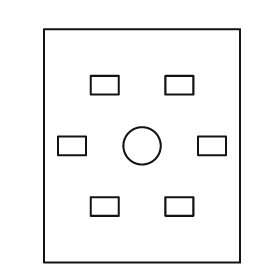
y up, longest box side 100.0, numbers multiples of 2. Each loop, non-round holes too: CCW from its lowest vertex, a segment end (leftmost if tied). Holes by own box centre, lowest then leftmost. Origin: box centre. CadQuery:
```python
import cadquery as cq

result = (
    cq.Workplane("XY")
    .moveTo(-42.0, -50.0)
    .lineTo(42.0, -50.0)
    .lineTo(42.0, 50.0)
    .lineTo(-42.0, 50.0)
    .close()
    .moveTo(-22.0, -30.0)
    .lineTo(-10.0, -30.0)
    .lineTo(-10.0, -22.0)
    .lineTo(-22.0, -22.0)
    .close()
    .moveTo(10.0, -30.0)
    .lineTo(22.0, -30.0)
    .lineTo(22.0, -22.0)
    .lineTo(10.0, -22.0)
    .close()
    .moveTo(-36.0, -4.0)
    .lineTo(-24.0, -4.0)
    .lineTo(-24.0, 4.0)
    .lineTo(-36.0, 4.0)
    .close()
    .moveTo(0.0, 0.0)
    .circle(8.0)
    .moveTo(24.0, -4.0)
    .lineTo(36.0, -4.0)
    .lineTo(36.0, 4.0)
    .lineTo(24.0, 4.0)
    .close()
    .moveTo(-22.0, 22.0)
    .lineTo(-10.0, 22.0)
    .lineTo(-10.0, 30.0)
    .lineTo(-22.0, 30.0)
    .close()
    .moveTo(10.0, 22.0)
    .lineTo(22.0, 22.0)
    .lineTo(22.0, 30.0)
    .lineTo(10.0, 30.0)
    .close()
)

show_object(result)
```